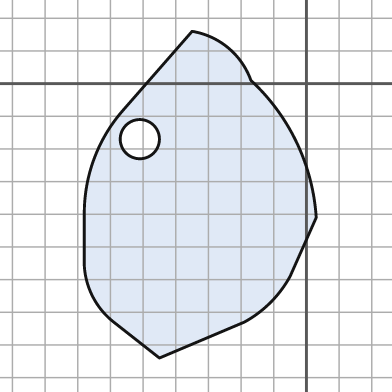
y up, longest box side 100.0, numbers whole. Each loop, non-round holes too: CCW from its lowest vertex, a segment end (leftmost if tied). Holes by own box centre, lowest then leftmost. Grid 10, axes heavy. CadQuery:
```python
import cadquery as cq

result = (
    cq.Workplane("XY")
    .moveTo(-45.0, -84.0)
    .lineTo(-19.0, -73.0)
    .threePointArc((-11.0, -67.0), (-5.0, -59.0))
    .lineTo(3.0, -41.0)
    .threePointArc((-3.0, -18.0), (-17.0, 1.0))
    .threePointArc((-24.0, 11.0), (-35.0, 16.0))
    .lineTo(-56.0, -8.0)
    .threePointArc((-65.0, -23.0), (-68.0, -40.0))
    .lineTo(-68.0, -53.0)
    .threePointArc((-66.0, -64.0), (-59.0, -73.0))
    .close()
    .moveTo(-51.0, -17.0)
    .circle(6.0)
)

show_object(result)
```